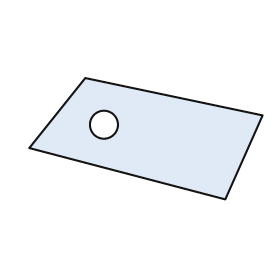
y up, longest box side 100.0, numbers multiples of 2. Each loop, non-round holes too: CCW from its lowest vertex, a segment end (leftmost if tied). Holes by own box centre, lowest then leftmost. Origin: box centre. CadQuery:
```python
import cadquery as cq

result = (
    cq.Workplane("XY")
    .moveTo(34.0, -26.0)
    .lineTo(50.0, 10.0)
    .lineTo(-26.0, 26.0)
    .lineTo(-50.0, -4.0)
    .close()
    .moveTo(-18.0, 6.0)
    .circle(6.0)
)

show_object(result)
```